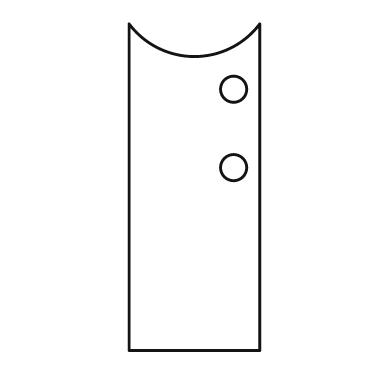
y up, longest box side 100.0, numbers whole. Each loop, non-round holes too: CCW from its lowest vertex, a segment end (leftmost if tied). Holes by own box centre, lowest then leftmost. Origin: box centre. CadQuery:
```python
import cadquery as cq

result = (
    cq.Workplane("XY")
    .moveTo(-20.0, -50.0)
    .lineTo(20.0, -50.0)
    .lineTo(20.0, 50.0)
    .threePointArc((0.0, 40.0), (-20.0, 50.0))
    .close()
    .moveTo(12.0, 6.0)
    .circle(4.0)
    .moveTo(12.0, 30.0)
    .circle(4.0)
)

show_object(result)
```